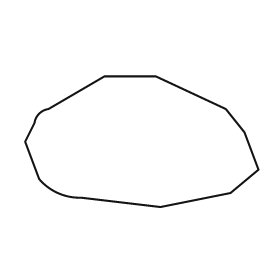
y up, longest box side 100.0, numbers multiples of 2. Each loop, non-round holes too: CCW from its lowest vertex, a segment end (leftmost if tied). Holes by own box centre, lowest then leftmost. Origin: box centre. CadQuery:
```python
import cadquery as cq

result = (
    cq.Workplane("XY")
    .moveTo(8.0, -28.0)
    .lineTo(38.0, -22.0)
    .lineTo(50.0, -12.0)
    .lineTo(44.0, 4.0)
    .lineTo(36.0, 14.0)
    .lineTo(6.0, 28.0)
    .lineTo(-16.0, 28.0)
    .lineTo(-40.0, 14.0)
    .threePointArc((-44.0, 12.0), (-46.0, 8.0))
    .lineTo(-50.0, 0.0)
    .lineTo(-44.0, -16.0)
    .threePointArc((-36.0, -22.0), (-26.0, -24.0))
    .close()
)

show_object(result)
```